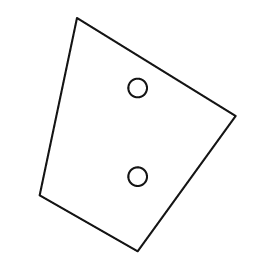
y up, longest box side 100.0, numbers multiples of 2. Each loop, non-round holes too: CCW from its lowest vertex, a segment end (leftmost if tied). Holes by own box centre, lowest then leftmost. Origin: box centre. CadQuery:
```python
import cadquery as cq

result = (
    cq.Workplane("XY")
    .moveTo(0.0, -50.0)
    .lineTo(42.0, 8.0)
    .lineTo(-26.0, 50.0)
    .lineTo(-42.0, -26.0)
    .close()
    .moveTo(0.0, -18.0)
    .circle(4.0)
    .moveTo(0.0, 20.0)
    .circle(4.0)
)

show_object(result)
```